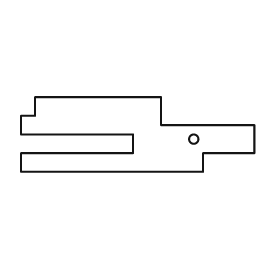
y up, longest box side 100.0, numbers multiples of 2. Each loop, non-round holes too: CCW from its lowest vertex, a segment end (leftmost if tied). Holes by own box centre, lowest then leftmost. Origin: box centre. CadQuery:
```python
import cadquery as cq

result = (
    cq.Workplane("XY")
    .moveTo(-50.0, -16.0)
    .lineTo(28.0, -16.0)
    .lineTo(28.0, -8.0)
    .lineTo(50.0, -8.0)
    .lineTo(50.0, 4.0)
    .lineTo(10.0, 4.0)
    .lineTo(10.0, 16.0)
    .lineTo(-44.0, 16.0)
    .lineTo(-44.0, 8.0)
    .lineTo(-50.0, 8.0)
    .lineTo(-50.0, 0.0)
    .lineTo(-2.0, 0.0)
    .lineTo(-2.0, -8.0)
    .lineTo(-50.0, -8.0)
    .close()
    .moveTo(24.0, -2.0)
    .circle(2.0)
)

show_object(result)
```